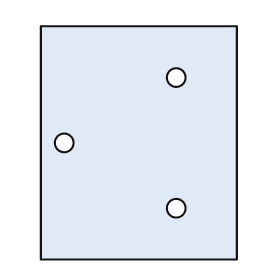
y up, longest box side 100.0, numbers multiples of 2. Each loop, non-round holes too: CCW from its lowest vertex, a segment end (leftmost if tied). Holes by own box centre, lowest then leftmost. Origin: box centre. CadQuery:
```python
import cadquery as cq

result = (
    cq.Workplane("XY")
    .moveTo(-42.0, -50.0)
    .lineTo(42.0, -50.0)
    .lineTo(42.0, 50.0)
    .lineTo(-42.0, 50.0)
    .close()
    .moveTo(16.0, -28.0)
    .circle(4.0)
    .moveTo(-32.0, 0.0)
    .circle(4.0)
    .moveTo(16.0, 28.0)
    .circle(4.0)
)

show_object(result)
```